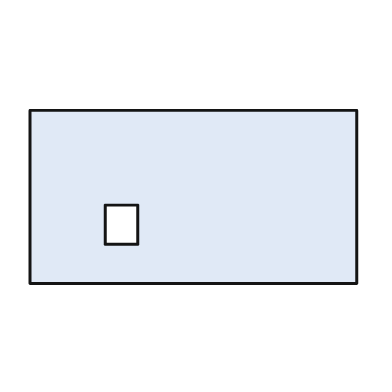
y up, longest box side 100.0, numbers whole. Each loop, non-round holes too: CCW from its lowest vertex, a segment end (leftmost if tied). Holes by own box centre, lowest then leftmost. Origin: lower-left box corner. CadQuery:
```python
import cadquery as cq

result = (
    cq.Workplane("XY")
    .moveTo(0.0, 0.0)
    .lineTo(100.0, 0.0)
    .lineTo(100.0, 53.0)
    .lineTo(0.0, 53.0)
    .close()
    .moveTo(23.0, 12.0)
    .lineTo(33.0, 12.0)
    .lineTo(33.0, 24.0)
    .lineTo(23.0, 24.0)
    .close()
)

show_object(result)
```